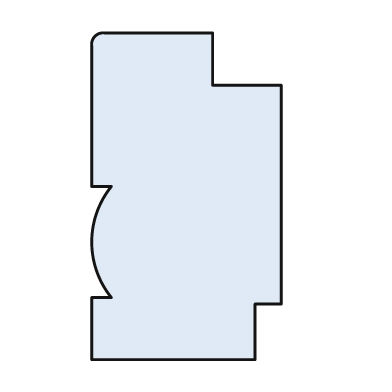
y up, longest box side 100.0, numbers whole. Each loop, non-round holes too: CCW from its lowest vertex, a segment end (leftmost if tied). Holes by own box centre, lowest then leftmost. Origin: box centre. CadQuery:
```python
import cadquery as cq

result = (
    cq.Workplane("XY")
    .moveTo(-29.0, -50.0)
    .lineTo(21.0, -50.0)
    .lineTo(21.0, -33.0)
    .lineTo(29.0, -33.0)
    .lineTo(29.0, 34.0)
    .lineTo(8.0, 34.0)
    .lineTo(8.0, 50.0)
    .lineTo(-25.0, 50.0)
    .threePointArc((-28.0, 49.0), (-29.0, 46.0))
    .lineTo(-29.0, 3.0)
    .lineTo(-23.0, 3.0)
    .threePointArc((-29.0, -14.0), (-23.0, -31.0))
    .lineTo(-29.0, -31.0)
    .close()
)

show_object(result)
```